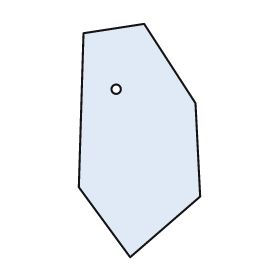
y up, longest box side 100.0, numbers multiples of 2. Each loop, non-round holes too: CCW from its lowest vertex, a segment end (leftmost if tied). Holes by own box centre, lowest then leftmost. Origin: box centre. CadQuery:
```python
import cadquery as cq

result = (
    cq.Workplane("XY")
    .moveTo(-4.0, -50.0)
    .lineTo(26.0, -24.0)
    .lineTo(24.0, 16.0)
    .lineTo(2.0, 50.0)
    .lineTo(-24.0, 46.0)
    .lineTo(-26.0, -20.0)
    .close()
    .moveTo(-10.0, 22.0)
    .circle(2.0)
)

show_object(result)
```